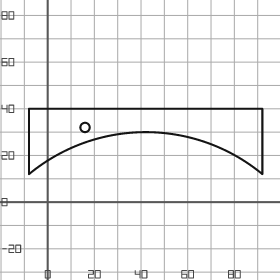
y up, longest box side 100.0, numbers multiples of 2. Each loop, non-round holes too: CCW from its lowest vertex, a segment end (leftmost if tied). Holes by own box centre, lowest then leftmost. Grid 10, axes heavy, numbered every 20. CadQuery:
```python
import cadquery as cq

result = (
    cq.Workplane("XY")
    .moveTo(-8.0, 12.0)
    .threePointArc((42.0, 30.0), (92.0, 12.0))
    .lineTo(92.0, 40.0)
    .lineTo(-8.0, 40.0)
    .close()
    .moveTo(16.0, 32.0)
    .circle(2.0)
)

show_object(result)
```